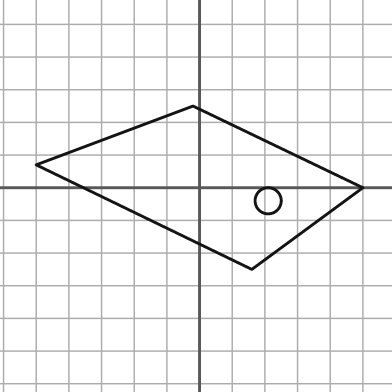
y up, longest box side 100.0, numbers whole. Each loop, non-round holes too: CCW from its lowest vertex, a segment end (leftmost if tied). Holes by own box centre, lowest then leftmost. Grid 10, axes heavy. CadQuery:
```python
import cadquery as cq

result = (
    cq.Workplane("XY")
    .moveTo(16.0, -25.0)
    .lineTo(50.0, 0.0)
    .lineTo(-2.0, 25.0)
    .lineTo(-50.0, 7.0)
    .close()
    .moveTo(21.0, -4.0)
    .circle(4.0)
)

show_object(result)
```